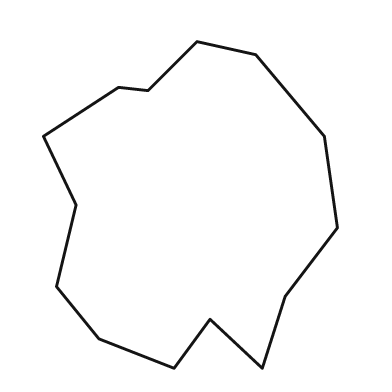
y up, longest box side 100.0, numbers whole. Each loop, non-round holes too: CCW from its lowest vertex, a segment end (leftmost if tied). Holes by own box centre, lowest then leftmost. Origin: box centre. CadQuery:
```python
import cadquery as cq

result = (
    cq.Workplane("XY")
    .moveTo(-5.0, -50.0)
    .lineTo(6.0, -35.0)
    .lineTo(22.0, -50.0)
    .lineTo(29.0, -28.0)
    .lineTo(45.0, -7.0)
    .lineTo(41.0, 21.0)
    .lineTo(20.0, 46.0)
    .lineTo(2.0, 50.0)
    .lineTo(-13.0, 35.0)
    .lineTo(-22.0, 36.0)
    .lineTo(-45.0, 21.0)
    .lineTo(-35.0, 0.0)
    .lineTo(-41.0, -25.0)
    .lineTo(-28.0, -41.0)
    .close()
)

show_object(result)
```